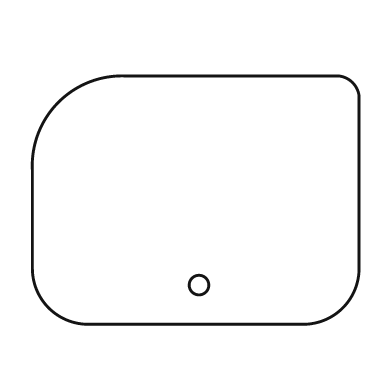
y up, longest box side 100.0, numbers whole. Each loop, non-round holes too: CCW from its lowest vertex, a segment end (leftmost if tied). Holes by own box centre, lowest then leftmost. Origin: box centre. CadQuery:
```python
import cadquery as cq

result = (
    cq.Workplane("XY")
    .moveTo(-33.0, -38.0)
    .lineTo(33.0, -38.0)
    .threePointArc((45.0, -33.0), (50.0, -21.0))
    .lineTo(50.0, 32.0)
    .threePointArc((48.0, 36.0), (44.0, 38.0))
    .lineTo(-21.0, 38.0)
    .threePointArc((-42.0, 30.0), (-50.0, 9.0))
    .lineTo(-50.0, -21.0)
    .threePointArc((-45.0, -33.0), (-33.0, -38.0))
    .close()
    .moveTo(1.0, -26.0)
    .circle(3.0)
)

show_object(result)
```